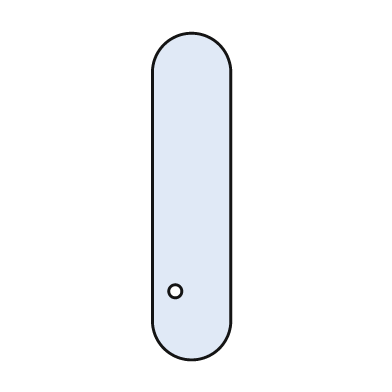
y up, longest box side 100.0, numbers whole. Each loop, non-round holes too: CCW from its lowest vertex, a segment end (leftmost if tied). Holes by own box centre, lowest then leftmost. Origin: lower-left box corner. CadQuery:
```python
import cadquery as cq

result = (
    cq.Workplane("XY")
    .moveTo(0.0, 12.0)
    .threePointArc((12.0, 0.0), (24.0, 12.0))
    .lineTo(24.0, 88.0)
    .threePointArc((12.0, 100.0), (0.0, 88.0))
    .close()
    .moveTo(7.0, 21.0)
    .circle(2.0)
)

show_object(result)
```